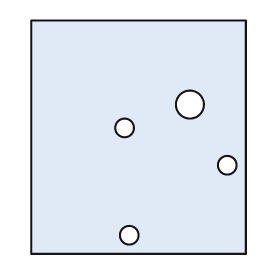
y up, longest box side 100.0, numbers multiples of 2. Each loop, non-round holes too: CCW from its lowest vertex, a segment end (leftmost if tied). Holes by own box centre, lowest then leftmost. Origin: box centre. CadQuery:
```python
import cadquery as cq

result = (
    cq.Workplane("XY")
    .moveTo(-46.0, -50.0)
    .lineTo(46.0, -50.0)
    .lineTo(46.0, 50.0)
    .lineTo(-46.0, 50.0)
    .close()
    .moveTo(-4.0, -42.0)
    .circle(4.0)
    .moveTo(38.0, -12.0)
    .circle(4.0)
    .moveTo(-6.0, 4.0)
    .circle(4.0)
    .moveTo(22.0, 14.0)
    .circle(6.0)
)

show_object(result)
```